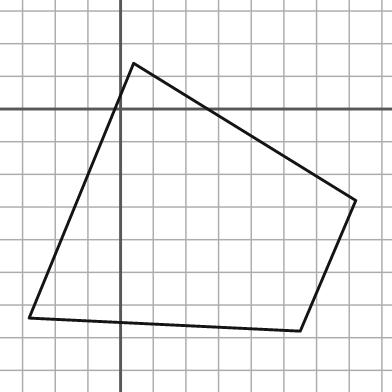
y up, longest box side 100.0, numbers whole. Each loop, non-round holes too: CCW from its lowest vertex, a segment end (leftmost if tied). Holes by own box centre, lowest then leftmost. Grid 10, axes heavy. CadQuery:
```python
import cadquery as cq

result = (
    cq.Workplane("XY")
    .moveTo(55.0, -68.0)
    .lineTo(72.0, -28.0)
    .lineTo(4.0, 14.0)
    .lineTo(-28.0, -64.0)
    .close()
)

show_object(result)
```